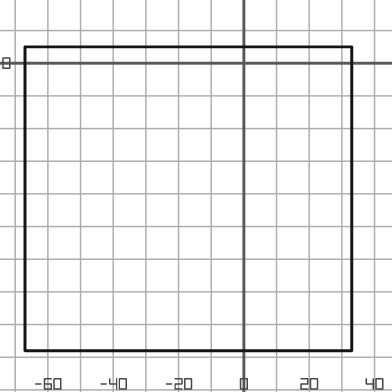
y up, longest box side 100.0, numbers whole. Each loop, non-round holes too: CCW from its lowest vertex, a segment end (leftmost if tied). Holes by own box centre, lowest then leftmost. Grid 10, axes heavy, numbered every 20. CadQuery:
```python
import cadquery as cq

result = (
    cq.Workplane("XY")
    .moveTo(-67.0, -88.0)
    .lineTo(33.0, -88.0)
    .lineTo(33.0, 5.0)
    .lineTo(-67.0, 5.0)
    .close()
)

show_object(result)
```